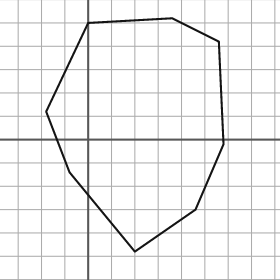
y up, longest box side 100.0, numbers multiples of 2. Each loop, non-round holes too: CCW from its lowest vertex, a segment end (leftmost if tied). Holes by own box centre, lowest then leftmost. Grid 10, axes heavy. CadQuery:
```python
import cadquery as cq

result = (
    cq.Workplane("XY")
    .moveTo(20.0, -48.0)
    .lineTo(46.0, -30.0)
    .lineTo(58.0, -2.0)
    .lineTo(56.0, 42.0)
    .lineTo(36.0, 52.0)
    .lineTo(0.0, 50.0)
    .lineTo(-18.0, 12.0)
    .lineTo(-8.0, -14.0)
    .close()
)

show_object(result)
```